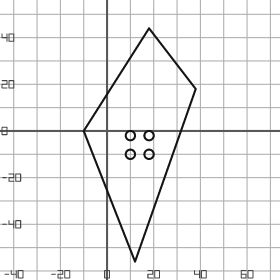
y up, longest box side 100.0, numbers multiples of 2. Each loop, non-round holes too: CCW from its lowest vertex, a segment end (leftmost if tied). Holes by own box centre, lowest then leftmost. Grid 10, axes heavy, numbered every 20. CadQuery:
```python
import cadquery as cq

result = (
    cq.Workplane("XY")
    .moveTo(12.0, -56.0)
    .lineTo(38.0, 18.0)
    .lineTo(18.0, 44.0)
    .lineTo(-10.0, 0.0)
    .close()
    .moveTo(10.0, -10.0)
    .circle(2.0)
    .moveTo(18.0, -10.0)
    .circle(2.0)
    .moveTo(10.0, -2.0)
    .circle(2.0)
    .moveTo(18.0, -2.0)
    .circle(2.0)
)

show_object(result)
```